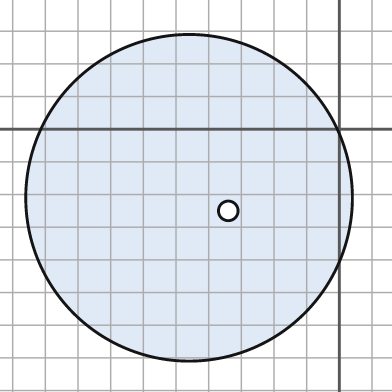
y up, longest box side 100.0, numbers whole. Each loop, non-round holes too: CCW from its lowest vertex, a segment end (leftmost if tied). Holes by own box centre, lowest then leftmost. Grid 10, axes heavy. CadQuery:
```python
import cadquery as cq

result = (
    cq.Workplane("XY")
    .moveTo(-46.0, -21.0)
    .circle(50.0)
    .moveTo(-34.0, -25.0)
    .circle(3.0)
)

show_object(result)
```